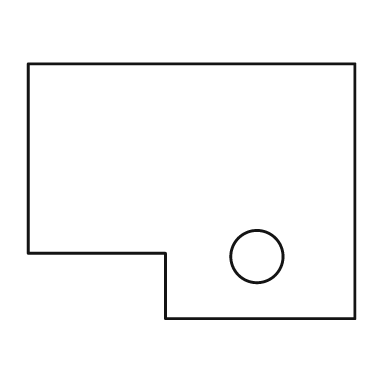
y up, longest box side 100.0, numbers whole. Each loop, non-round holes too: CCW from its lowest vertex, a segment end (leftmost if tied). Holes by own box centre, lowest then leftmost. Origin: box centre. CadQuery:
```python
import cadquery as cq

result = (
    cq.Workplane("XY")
    .moveTo(-8.0, -39.0)
    .lineTo(50.0, -39.0)
    .lineTo(50.0, 39.0)
    .lineTo(-50.0, 39.0)
    .lineTo(-50.0, -19.0)
    .lineTo(-8.0, -19.0)
    .close()
    .moveTo(20.0, -20.0)
    .circle(8.0)
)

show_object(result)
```